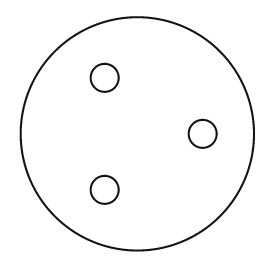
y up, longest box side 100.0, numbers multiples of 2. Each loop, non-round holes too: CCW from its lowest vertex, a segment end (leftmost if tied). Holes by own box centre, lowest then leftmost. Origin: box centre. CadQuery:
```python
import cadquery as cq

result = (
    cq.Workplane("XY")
    .moveTo(0.0, 0.0)
    .circle(50.0)
    .moveTo(-14.0, -24.0)
    .circle(6.0)
    .moveTo(28.0, 0.0)
    .circle(6.0)
    .moveTo(-14.0, 24.0)
    .circle(6.0)
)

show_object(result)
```